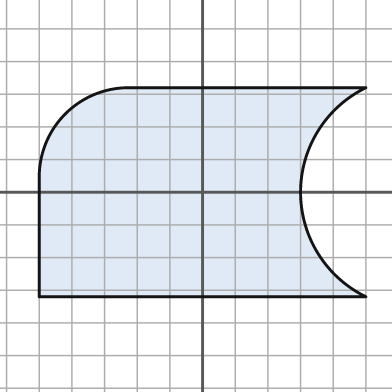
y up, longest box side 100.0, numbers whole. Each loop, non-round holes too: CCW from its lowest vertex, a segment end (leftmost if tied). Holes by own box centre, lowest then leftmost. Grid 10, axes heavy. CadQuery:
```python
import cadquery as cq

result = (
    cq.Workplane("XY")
    .moveTo(-50.0, -32.0)
    .lineTo(50.0, -32.0)
    .threePointArc((30.0, 0.0), (50.0, 32.0))
    .lineTo(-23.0, 32.0)
    .threePointArc((-42.0, 24.0), (-50.0, 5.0))
    .close()
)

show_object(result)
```